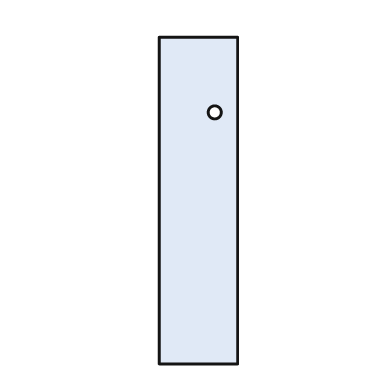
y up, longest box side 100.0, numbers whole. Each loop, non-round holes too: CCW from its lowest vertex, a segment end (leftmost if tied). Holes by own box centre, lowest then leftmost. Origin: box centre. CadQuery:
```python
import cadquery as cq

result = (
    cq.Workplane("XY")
    .moveTo(-12.0, -50.0)
    .lineTo(12.0, -50.0)
    .lineTo(12.0, 50.0)
    .lineTo(-12.0, 50.0)
    .close()
    .moveTo(5.0, 27.0)
    .circle(2.0)
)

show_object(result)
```